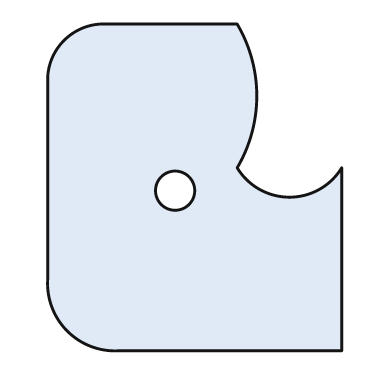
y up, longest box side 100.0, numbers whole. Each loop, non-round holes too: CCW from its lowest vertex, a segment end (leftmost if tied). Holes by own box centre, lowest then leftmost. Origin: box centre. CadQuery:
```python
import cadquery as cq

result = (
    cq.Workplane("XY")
    .moveTo(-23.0, -50.0)
    .lineTo(45.0, -50.0)
    .lineTo(45.0, 6.0)
    .threePointArc((29.0, -3.0), (13.0, 6.0))
    .threePointArc((19.0, 28.0), (13.0, 50.0))
    .lineTo(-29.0, 50.0)
    .threePointArc((-40.0, 45.0), (-45.0, 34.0))
    .lineTo(-45.0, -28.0)
    .threePointArc((-39.0, -44.0), (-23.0, -50.0))
    .close()
    .moveTo(-6.0, -1.0)
    .circle(6.0)
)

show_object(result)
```